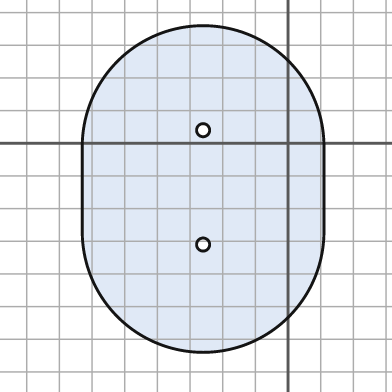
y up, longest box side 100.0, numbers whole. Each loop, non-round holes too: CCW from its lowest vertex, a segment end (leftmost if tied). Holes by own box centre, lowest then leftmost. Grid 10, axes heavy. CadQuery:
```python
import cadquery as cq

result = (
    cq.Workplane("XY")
    .moveTo(-63.0, -27.0)
    .threePointArc((-26.0, -64.0), (11.0, -27.0))
    .lineTo(11.0, -1.0)
    .threePointArc((-26.0, 36.0), (-63.0, -1.0))
    .close()
    .moveTo(-26.0, -31.0)
    .circle(2.0)
    .moveTo(-26.0, 4.0)
    .circle(2.0)
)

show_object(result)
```